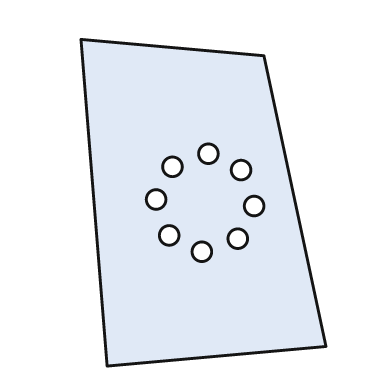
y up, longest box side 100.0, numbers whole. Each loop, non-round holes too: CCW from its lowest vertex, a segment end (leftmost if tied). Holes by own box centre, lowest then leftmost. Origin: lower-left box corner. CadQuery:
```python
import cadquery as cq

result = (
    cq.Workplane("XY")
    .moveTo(8.0, 0.0)
    .lineTo(75.0, 6.0)
    .lineTo(56.0, 95.0)
    .lineTo(0.0, 100.0)
    .close()
    .moveTo(37.0, 35.0)
    .circle(3.0)
    .moveTo(48.0, 39.0)
    .circle(3.0)
    .moveTo(27.0, 40.0)
    .circle(3.0)
    .moveTo(53.0, 49.0)
    .circle(3.0)
    .moveTo(23.0, 51.0)
    .circle(3.0)
    .moveTo(49.0, 60.0)
    .circle(3.0)
    .moveTo(28.0, 61.0)
    .circle(3.0)
    .moveTo(39.0, 65.0)
    .circle(3.0)
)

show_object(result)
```